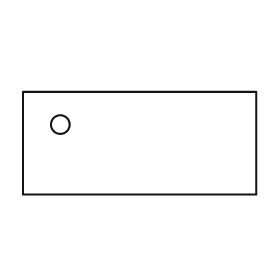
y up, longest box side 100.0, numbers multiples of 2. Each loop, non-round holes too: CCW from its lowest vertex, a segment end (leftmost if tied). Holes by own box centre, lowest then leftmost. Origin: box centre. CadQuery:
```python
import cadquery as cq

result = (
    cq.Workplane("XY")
    .moveTo(-50.0, -22.0)
    .lineTo(50.0, -22.0)
    .lineTo(50.0, 22.0)
    .lineTo(-50.0, 22.0)
    .close()
    .moveTo(-34.0, 8.0)
    .circle(4.0)
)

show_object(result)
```